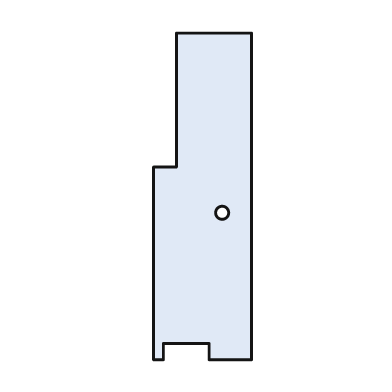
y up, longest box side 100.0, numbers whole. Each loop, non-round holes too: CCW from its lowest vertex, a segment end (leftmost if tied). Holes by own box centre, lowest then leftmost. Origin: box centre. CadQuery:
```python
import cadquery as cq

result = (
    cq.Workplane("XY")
    .moveTo(-15.0, -50.0)
    .lineTo(-12.0, -50.0)
    .lineTo(-12.0, -45.0)
    .lineTo(2.0, -45.0)
    .lineTo(2.0, -50.0)
    .lineTo(15.0, -50.0)
    .lineTo(15.0, 50.0)
    .lineTo(-8.0, 50.0)
    .lineTo(-8.0, 9.0)
    .lineTo(-15.0, 9.0)
    .close()
    .moveTo(6.0, -5.0)
    .circle(2.0)
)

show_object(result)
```